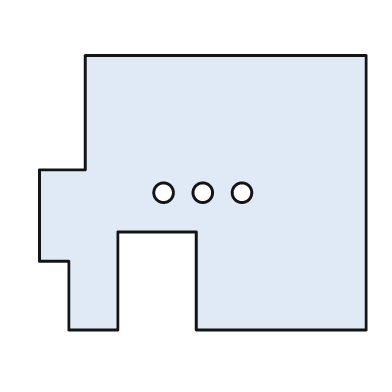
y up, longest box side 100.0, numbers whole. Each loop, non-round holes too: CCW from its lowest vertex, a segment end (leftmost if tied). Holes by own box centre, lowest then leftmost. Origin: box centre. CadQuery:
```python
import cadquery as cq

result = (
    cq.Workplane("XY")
    .moveTo(-41.0, -42.0)
    .lineTo(-26.0, -42.0)
    .lineTo(-26.0, -12.0)
    .lineTo(-2.0, -12.0)
    .lineTo(-2.0, -42.0)
    .lineTo(50.0, -42.0)
    .lineTo(50.0, 42.0)
    .lineTo(-36.0, 42.0)
    .lineTo(-36.0, 7.0)
    .lineTo(-50.0, 7.0)
    .lineTo(-50.0, -21.0)
    .lineTo(-41.0, -21.0)
    .close()
    .moveTo(-12.0, 0.0)
    .circle(3.0)
    .moveTo(0.0, 0.0)
    .circle(3.0)
    .moveTo(12.0, 0.0)
    .circle(3.0)
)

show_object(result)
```